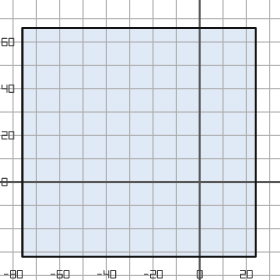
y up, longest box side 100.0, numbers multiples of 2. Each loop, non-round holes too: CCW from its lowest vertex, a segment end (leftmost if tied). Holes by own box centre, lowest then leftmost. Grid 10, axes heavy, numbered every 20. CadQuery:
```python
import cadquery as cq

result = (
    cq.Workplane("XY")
    .moveTo(-76.0, -32.0)
    .lineTo(24.0, -32.0)
    .lineTo(24.0, 66.0)
    .lineTo(-76.0, 66.0)
    .close()
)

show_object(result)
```